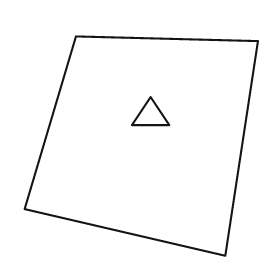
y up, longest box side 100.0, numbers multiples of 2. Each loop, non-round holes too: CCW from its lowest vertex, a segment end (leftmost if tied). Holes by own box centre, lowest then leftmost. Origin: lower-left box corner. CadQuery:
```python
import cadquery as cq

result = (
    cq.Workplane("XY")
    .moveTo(86.0, 0.0)
    .lineTo(100.0, 92.0)
    .lineTo(22.0, 94.0)
    .lineTo(0.0, 20.0)
    .close()
    .moveTo(46.0, 56.0)
    .lineTo(62.0, 56.0)
    .lineTo(54.0, 68.0)
    .close()
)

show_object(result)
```